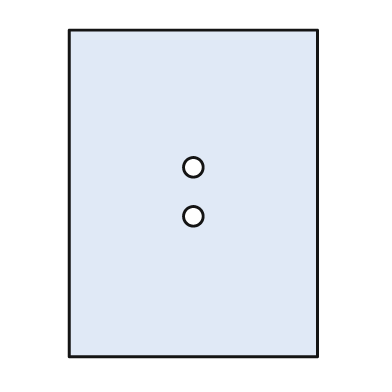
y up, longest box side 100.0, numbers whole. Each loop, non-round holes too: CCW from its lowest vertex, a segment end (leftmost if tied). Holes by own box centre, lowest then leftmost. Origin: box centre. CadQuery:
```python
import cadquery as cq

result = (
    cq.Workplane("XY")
    .moveTo(-38.0, -50.0)
    .lineTo(38.0, -50.0)
    .lineTo(38.0, 50.0)
    .lineTo(-38.0, 50.0)
    .close()
    .moveTo(0.0, -7.0)
    .circle(3.0)
    .moveTo(0.0, 8.0)
    .circle(3.0)
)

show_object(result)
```